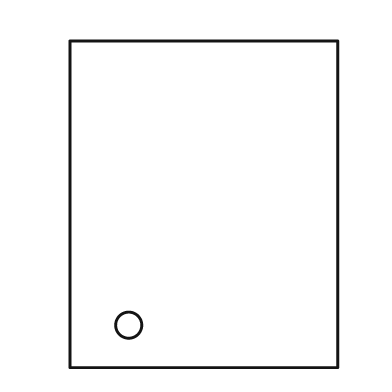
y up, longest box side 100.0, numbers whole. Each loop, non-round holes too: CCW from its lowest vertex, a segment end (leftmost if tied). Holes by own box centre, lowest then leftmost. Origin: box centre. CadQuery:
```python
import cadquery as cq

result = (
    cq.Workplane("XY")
    .moveTo(-41.0, -50.0)
    .lineTo(41.0, -50.0)
    .lineTo(41.0, 50.0)
    .lineTo(-41.0, 50.0)
    .close()
    .moveTo(-23.0, -37.0)
    .circle(4.0)
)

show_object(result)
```